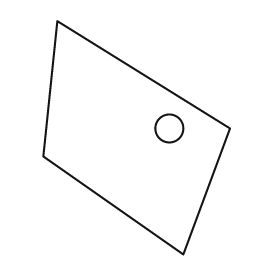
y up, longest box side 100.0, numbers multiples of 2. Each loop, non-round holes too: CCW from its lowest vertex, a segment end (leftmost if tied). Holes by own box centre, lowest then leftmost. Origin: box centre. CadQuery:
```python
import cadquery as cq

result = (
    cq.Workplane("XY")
    .moveTo(20.0, -50.0)
    .lineTo(40.0, 4.0)
    .lineTo(-34.0, 50.0)
    .lineTo(-40.0, -8.0)
    .close()
    .moveTo(14.0, 4.0)
    .circle(6.0)
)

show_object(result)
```